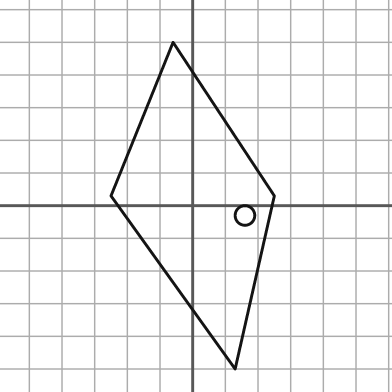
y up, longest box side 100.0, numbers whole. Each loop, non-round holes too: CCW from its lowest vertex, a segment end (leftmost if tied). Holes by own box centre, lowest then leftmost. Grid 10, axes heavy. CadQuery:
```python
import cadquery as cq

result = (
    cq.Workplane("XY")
    .moveTo(13.0, -50.0)
    .lineTo(25.0, 3.0)
    .lineTo(-6.0, 50.0)
    .lineTo(-25.0, 3.0)
    .close()
    .moveTo(16.0, -3.0)
    .circle(3.0)
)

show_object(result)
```